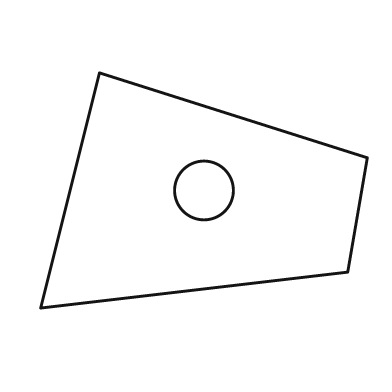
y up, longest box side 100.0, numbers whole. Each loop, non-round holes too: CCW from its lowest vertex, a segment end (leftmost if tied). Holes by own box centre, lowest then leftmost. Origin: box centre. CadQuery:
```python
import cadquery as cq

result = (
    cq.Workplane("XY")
    .moveTo(-50.0, -36.0)
    .lineTo(44.0, -25.0)
    .lineTo(50.0, 10.0)
    .lineTo(-32.0, 36.0)
    .close()
    .moveTo(0.0, 0.0)
    .circle(9.0)
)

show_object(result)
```